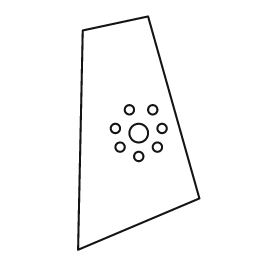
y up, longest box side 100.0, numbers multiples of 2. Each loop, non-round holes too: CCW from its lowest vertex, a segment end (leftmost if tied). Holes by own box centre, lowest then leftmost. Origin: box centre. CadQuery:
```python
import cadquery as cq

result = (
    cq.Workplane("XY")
    .moveTo(-26.0, -50.0)
    .lineTo(26.0, -28.0)
    .lineTo(4.0, 50.0)
    .lineTo(-24.0, 44.0)
    .close()
    .moveTo(0.0, -10.0)
    .circle(2.0)
    .moveTo(-8.0, -6.0)
    .circle(2.0)
    .moveTo(8.0, -6.0)
    .circle(2.0)
    .moveTo(0.0, 0.0)
    .circle(4.0)
    .moveTo(-10.0, 2.0)
    .circle(2.0)
    .moveTo(10.0, 2.0)
    .circle(2.0)
    .moveTo(-4.0, 10.0)
    .circle(2.0)
    .moveTo(6.0, 10.0)
    .circle(2.0)
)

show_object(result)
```